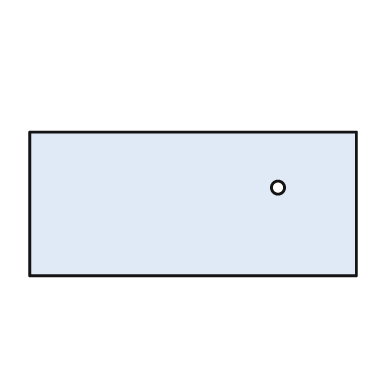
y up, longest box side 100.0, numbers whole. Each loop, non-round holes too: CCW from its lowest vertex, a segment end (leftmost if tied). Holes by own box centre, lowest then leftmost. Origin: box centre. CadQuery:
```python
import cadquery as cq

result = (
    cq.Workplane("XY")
    .moveTo(-50.0, -22.0)
    .lineTo(50.0, -22.0)
    .lineTo(50.0, 22.0)
    .lineTo(-50.0, 22.0)
    .close()
    .moveTo(26.0, 5.0)
    .circle(2.0)
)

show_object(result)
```